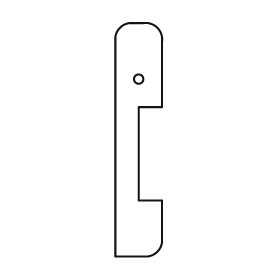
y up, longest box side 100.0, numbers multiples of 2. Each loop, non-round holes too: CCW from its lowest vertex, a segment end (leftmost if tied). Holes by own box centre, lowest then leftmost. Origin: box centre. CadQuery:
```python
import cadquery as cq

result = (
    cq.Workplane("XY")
    .moveTo(-10.0, -50.0)
    .lineTo(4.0, -50.0)
    .threePointArc((8.0, -48.0), (10.0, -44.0))
    .lineTo(10.0, -26.0)
    .lineTo(0.0, -26.0)
    .lineTo(0.0, 14.0)
    .lineTo(10.0, 14.0)
    .lineTo(10.0, 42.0)
    .threePointArc((8.0, 48.0), (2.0, 50.0))
    .lineTo(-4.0, 50.0)
    .threePointArc((-8.0, 48.0), (-10.0, 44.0))
    .close()
    .moveTo(0.0, 26.0)
    .circle(2.0)
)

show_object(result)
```